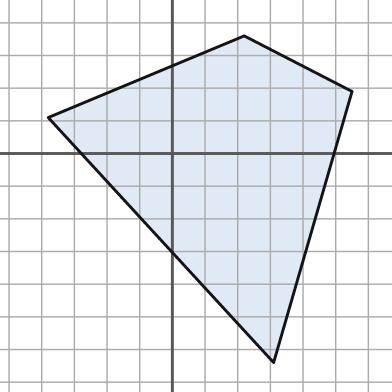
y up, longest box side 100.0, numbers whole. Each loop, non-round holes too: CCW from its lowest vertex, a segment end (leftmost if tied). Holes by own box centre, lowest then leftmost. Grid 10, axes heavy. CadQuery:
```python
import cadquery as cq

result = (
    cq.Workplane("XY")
    .moveTo(31.0, -64.0)
    .lineTo(55.0, 19.0)
    .lineTo(22.0, 36.0)
    .lineTo(-38.0, 11.0)
    .close()
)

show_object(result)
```